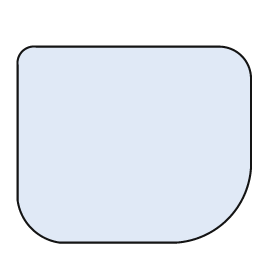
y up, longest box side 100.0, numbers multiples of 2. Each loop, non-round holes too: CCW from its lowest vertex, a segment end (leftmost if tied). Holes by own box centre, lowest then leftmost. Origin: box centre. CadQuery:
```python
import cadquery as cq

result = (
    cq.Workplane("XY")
    .moveTo(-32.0, -42.0)
    .lineTo(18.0, -42.0)
    .threePointArc((40.0, -32.0), (50.0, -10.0))
    .lineTo(50.0, 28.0)
    .threePointArc((46.0, 38.0), (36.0, 42.0))
    .lineTo(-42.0, 42.0)
    .threePointArc((-48.0, 40.0), (-50.0, 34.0))
    .lineTo(-50.0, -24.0)
    .threePointArc((-44.0, -36.0), (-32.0, -42.0))
    .close()
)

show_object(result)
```